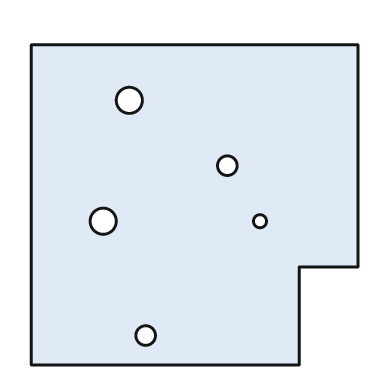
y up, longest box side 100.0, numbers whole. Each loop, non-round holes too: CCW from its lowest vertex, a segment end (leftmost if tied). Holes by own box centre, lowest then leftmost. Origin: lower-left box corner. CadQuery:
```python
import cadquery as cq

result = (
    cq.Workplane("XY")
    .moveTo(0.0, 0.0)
    .lineTo(82.0, 0.0)
    .lineTo(82.0, 30.0)
    .lineTo(100.0, 30.0)
    .lineTo(100.0, 98.0)
    .lineTo(0.0, 98.0)
    .close()
    .moveTo(35.0, 9.0)
    .circle(3.0)
    .moveTo(22.0, 44.0)
    .circle(4.0)
    .moveTo(70.0, 44.0)
    .circle(2.0)
    .moveTo(60.0, 61.0)
    .circle(3.0)
    .moveTo(30.0, 81.0)
    .circle(4.0)
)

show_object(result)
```